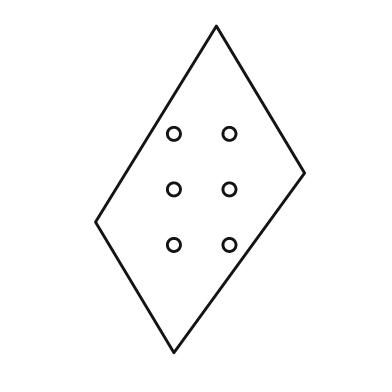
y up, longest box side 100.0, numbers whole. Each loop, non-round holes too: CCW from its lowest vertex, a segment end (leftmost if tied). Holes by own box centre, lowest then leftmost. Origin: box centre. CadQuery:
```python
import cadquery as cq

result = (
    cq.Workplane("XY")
    .moveTo(-8.0, -50.0)
    .lineTo(32.0, 5.0)
    .lineTo(5.0, 50.0)
    .lineTo(-32.0, -10.0)
    .close()
    .moveTo(-8.0, -17.0)
    .circle(2.0)
    .moveTo(9.0, -17.0)
    .circle(2.0)
    .moveTo(-8.0, 0.0)
    .circle(2.0)
    .moveTo(9.0, 0.0)
    .circle(2.0)
    .moveTo(-8.0, 17.0)
    .circle(2.0)
    .moveTo(9.0, 17.0)
    .circle(2.0)
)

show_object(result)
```